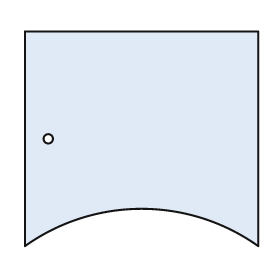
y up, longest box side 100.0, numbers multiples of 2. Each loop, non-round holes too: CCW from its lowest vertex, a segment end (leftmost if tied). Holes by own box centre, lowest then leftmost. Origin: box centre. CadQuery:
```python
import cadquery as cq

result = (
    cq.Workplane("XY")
    .moveTo(-50.0, -46.0)
    .threePointArc((0.0, -30.0), (50.0, -46.0))
    .lineTo(50.0, 46.0)
    .lineTo(-50.0, 46.0)
    .close()
    .moveTo(-40.0, 0.0)
    .circle(2.0)
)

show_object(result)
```